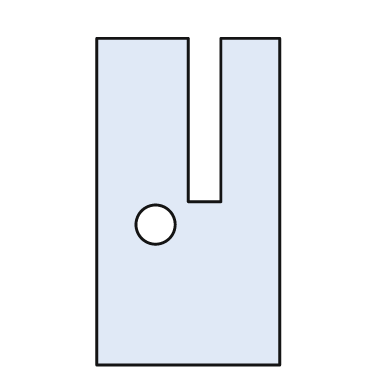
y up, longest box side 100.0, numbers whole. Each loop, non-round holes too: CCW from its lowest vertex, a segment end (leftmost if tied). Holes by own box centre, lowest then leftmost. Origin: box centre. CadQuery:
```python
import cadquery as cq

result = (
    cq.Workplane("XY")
    .moveTo(-28.0, -50.0)
    .lineTo(28.0, -50.0)
    .lineTo(28.0, 50.0)
    .lineTo(10.0, 50.0)
    .lineTo(10.0, 0.0)
    .lineTo(0.0, 0.0)
    .lineTo(0.0, 50.0)
    .lineTo(-28.0, 50.0)
    .close()
    .moveTo(-10.0, -7.0)
    .circle(6.0)
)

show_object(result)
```